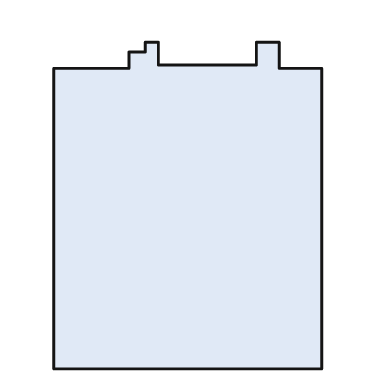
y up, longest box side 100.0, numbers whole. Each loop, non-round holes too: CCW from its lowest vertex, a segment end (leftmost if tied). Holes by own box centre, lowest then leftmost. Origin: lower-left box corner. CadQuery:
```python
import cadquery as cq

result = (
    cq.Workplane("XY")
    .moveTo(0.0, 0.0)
    .lineTo(82.0, 0.0)
    .lineTo(82.0, 92.0)
    .lineTo(69.0, 92.0)
    .lineTo(69.0, 100.0)
    .lineTo(62.0, 100.0)
    .lineTo(62.0, 93.0)
    .lineTo(32.0, 93.0)
    .lineTo(32.0, 100.0)
    .lineTo(28.0, 100.0)
    .lineTo(28.0, 97.0)
    .lineTo(23.0, 97.0)
    .lineTo(23.0, 92.0)
    .lineTo(0.0, 92.0)
    .close()
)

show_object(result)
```